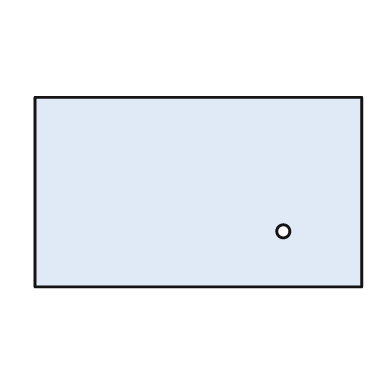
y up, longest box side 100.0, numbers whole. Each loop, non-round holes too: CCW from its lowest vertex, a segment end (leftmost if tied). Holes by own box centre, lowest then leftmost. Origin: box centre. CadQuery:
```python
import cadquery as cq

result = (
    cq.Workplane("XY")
    .moveTo(-50.0, -29.0)
    .lineTo(50.0, -29.0)
    .lineTo(50.0, 29.0)
    .lineTo(-50.0, 29.0)
    .close()
    .moveTo(26.0, -12.0)
    .circle(2.0)
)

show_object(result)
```